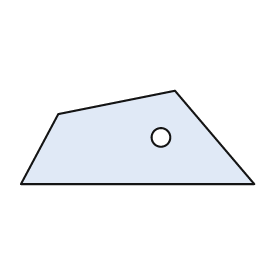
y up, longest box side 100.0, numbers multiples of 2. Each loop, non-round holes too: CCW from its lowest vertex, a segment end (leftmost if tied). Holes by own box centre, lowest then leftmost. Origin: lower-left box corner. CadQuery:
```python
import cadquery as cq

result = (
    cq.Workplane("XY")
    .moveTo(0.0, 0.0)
    .lineTo(100.0, 0.0)
    .lineTo(66.0, 40.0)
    .lineTo(16.0, 30.0)
    .close()
    .moveTo(60.0, 20.0)
    .circle(4.0)
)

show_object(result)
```